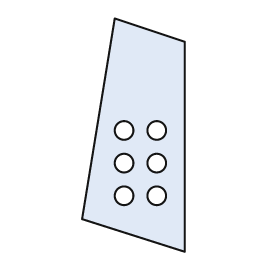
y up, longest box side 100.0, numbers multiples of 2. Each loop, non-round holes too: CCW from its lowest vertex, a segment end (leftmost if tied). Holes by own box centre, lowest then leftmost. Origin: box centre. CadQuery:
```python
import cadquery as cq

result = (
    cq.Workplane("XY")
    .moveTo(22.0, -50.0)
    .lineTo(22.0, 40.0)
    .lineTo(-8.0, 50.0)
    .lineTo(-22.0, -36.0)
    .close()
    .moveTo(-4.0, -26.0)
    .circle(4.0)
    .moveTo(10.0, -26.0)
    .circle(4.0)
    .moveTo(-4.0, -12.0)
    .circle(4.0)
    .moveTo(10.0, -12.0)
    .circle(4.0)
    .moveTo(-4.0, 2.0)
    .circle(4.0)
    .moveTo(10.0, 2.0)
    .circle(4.0)
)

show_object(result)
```